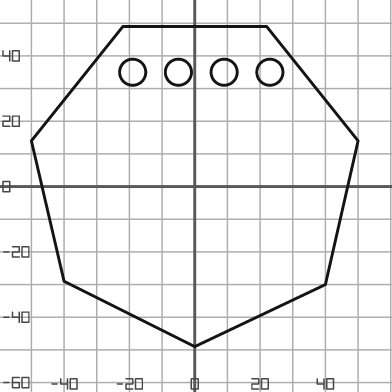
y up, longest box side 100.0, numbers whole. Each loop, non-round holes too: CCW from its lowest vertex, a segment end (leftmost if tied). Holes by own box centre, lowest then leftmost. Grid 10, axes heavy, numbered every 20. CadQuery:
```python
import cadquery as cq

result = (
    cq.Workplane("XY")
    .moveTo(0.0, -49.0)
    .lineTo(40.0, -30.0)
    .lineTo(50.0, 14.0)
    .lineTo(22.0, 49.0)
    .lineTo(-22.0, 49.0)
    .lineTo(-50.0, 14.0)
    .lineTo(-40.0, -29.0)
    .close()
    .moveTo(-19.0, 35.0)
    .circle(4.0)
    .moveTo(-5.0, 35.0)
    .circle(4.0)
    .moveTo(9.0, 35.0)
    .circle(4.0)
    .moveTo(23.0, 35.0)
    .circle(4.0)
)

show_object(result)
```